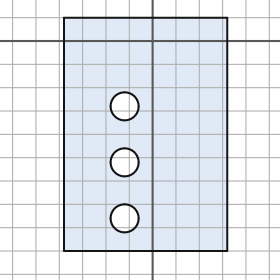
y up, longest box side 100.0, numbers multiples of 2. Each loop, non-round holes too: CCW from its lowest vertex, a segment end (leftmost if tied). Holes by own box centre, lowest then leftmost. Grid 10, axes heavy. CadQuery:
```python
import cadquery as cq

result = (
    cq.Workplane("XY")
    .moveTo(-38.0, -90.0)
    .lineTo(32.0, -90.0)
    .lineTo(32.0, 10.0)
    .lineTo(-38.0, 10.0)
    .close()
    .moveTo(-12.0, -76.0)
    .circle(6.0)
    .moveTo(-12.0, -52.0)
    .circle(6.0)
    .moveTo(-12.0, -28.0)
    .circle(6.0)
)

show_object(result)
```